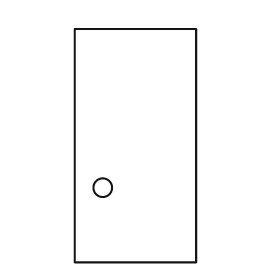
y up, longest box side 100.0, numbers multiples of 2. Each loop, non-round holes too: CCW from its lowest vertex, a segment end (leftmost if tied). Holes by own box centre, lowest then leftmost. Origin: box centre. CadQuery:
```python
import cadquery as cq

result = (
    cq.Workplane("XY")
    .moveTo(-26.0, -50.0)
    .lineTo(26.0, -50.0)
    .lineTo(26.0, 50.0)
    .lineTo(-26.0, 50.0)
    .close()
    .moveTo(-14.0, -18.0)
    .circle(4.0)
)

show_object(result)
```